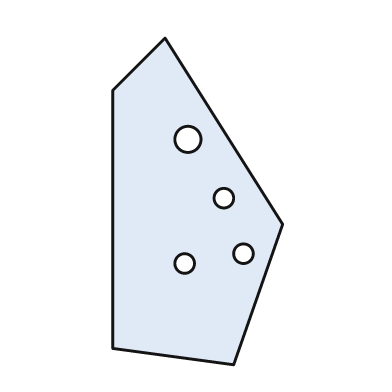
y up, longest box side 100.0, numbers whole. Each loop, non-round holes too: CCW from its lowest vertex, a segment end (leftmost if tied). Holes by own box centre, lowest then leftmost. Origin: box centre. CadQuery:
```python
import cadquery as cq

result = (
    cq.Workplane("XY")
    .moveTo(11.0, -50.0)
    .lineTo(26.0, -7.0)
    .lineTo(-10.0, 50.0)
    .lineTo(-26.0, 34.0)
    .lineTo(-26.0, -45.0)
    .close()
    .moveTo(-4.0, -19.0)
    .circle(3.0)
    .moveTo(14.0, -16.0)
    .circle(3.0)
    .moveTo(8.0, 1.0)
    .circle(3.0)
    .moveTo(-3.0, 19.0)
    .circle(4.0)
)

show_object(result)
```